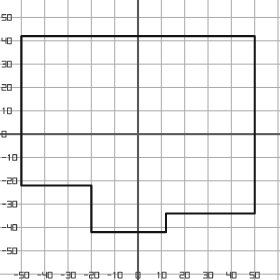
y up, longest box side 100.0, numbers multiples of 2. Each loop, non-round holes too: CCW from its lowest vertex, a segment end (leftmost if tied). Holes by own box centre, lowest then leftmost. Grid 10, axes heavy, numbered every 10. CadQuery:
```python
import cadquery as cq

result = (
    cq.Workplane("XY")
    .moveTo(-20.0, -42.0)
    .lineTo(12.0, -42.0)
    .lineTo(12.0, -34.0)
    .lineTo(50.0, -34.0)
    .lineTo(50.0, 42.0)
    .lineTo(-50.0, 42.0)
    .lineTo(-50.0, -22.0)
    .lineTo(-20.0, -22.0)
    .close()
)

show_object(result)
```